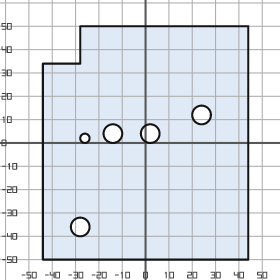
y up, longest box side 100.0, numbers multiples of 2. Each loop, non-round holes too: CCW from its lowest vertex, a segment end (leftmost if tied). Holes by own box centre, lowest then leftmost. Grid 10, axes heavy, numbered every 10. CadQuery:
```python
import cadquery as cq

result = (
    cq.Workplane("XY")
    .moveTo(-44.0, -50.0)
    .lineTo(44.0, -50.0)
    .lineTo(44.0, 50.0)
    .lineTo(-28.0, 50.0)
    .lineTo(-28.0, 34.0)
    .lineTo(-44.0, 34.0)
    .close()
    .moveTo(-28.0, -36.0)
    .circle(4.0)
    .moveTo(-26.0, 2.0)
    .circle(2.0)
    .moveTo(-14.0, 4.0)
    .circle(4.0)
    .moveTo(2.0, 4.0)
    .circle(4.0)
    .moveTo(24.0, 12.0)
    .circle(4.0)
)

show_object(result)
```